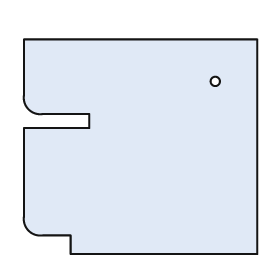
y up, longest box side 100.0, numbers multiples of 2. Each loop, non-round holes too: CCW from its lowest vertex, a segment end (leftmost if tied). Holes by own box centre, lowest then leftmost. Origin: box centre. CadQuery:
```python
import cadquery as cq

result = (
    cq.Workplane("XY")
    .moveTo(-30.0, -46.0)
    .lineTo(50.0, -46.0)
    .lineTo(50.0, 46.0)
    .lineTo(-50.0, 46.0)
    .lineTo(-50.0, 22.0)
    .threePointArc((-48.0, 16.0), (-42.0, 14.0))
    .lineTo(-22.0, 14.0)
    .lineTo(-22.0, 8.0)
    .lineTo(-50.0, 8.0)
    .lineTo(-50.0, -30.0)
    .threePointArc((-48.0, -36.0), (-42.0, -38.0))
    .lineTo(-30.0, -38.0)
    .close()
    .moveTo(32.0, 28.0)
    .circle(2.0)
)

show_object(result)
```